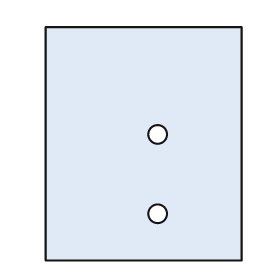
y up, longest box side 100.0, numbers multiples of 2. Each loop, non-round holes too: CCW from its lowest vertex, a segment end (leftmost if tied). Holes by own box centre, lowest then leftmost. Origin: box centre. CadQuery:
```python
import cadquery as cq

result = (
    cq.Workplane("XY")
    .moveTo(-42.0, -50.0)
    .lineTo(42.0, -50.0)
    .lineTo(42.0, 50.0)
    .lineTo(-42.0, 50.0)
    .close()
    .moveTo(6.0, -30.0)
    .circle(4.0)
    .moveTo(6.0, 4.0)
    .circle(4.0)
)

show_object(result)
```